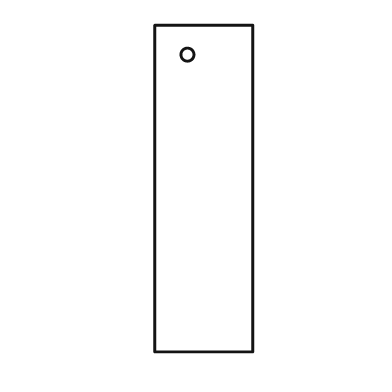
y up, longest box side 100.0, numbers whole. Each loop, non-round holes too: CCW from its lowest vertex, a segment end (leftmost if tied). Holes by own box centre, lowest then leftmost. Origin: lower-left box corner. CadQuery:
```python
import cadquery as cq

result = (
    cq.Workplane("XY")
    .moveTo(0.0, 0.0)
    .lineTo(30.0, 0.0)
    .lineTo(30.0, 100.0)
    .lineTo(0.0, 100.0)
    .close()
    .moveTo(10.0, 91.0)
    .circle(2.0)
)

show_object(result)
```